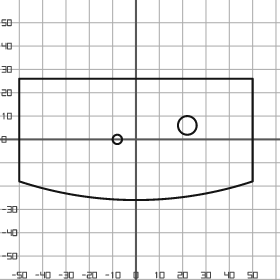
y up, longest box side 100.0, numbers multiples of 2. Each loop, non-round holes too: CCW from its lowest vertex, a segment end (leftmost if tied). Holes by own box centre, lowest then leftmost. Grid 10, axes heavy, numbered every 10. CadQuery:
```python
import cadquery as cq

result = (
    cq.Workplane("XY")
    .moveTo(-50.0, -18.0)
    .threePointArc((0.0, -26.0), (50.0, -18.0))
    .lineTo(50.0, 26.0)
    .lineTo(-50.0, 26.0)
    .close()
    .moveTo(-8.0, 0.0)
    .circle(2.0)
    .moveTo(22.0, 6.0)
    .circle(4.0)
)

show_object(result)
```